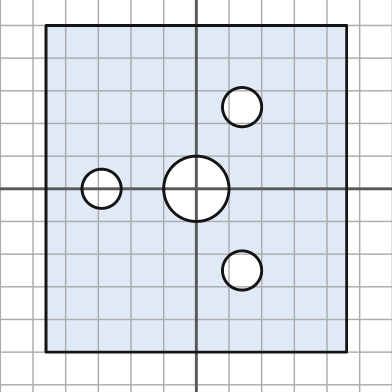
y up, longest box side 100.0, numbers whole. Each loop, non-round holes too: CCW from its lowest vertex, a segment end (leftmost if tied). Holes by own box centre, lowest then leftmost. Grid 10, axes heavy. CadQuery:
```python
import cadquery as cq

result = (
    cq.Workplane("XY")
    .moveTo(-46.0, -50.0)
    .lineTo(46.0, -50.0)
    .lineTo(46.0, 50.0)
    .lineTo(-46.0, 50.0)
    .close()
    .moveTo(14.0, -25.0)
    .circle(6.0)
    .moveTo(-29.0, 0.0)
    .circle(6.0)
    .moveTo(0.0, 0.0)
    .circle(10.0)
    .moveTo(14.0, 25.0)
    .circle(6.0)
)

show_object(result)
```